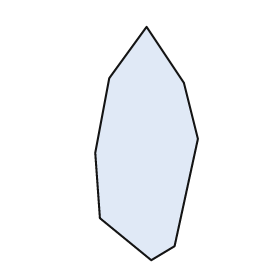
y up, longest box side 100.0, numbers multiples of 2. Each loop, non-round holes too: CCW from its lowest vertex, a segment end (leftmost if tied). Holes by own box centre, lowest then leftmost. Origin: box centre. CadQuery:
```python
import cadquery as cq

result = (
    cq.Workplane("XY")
    .moveTo(2.0, -50.0)
    .lineTo(12.0, -44.0)
    .lineTo(22.0, 2.0)
    .lineTo(16.0, 26.0)
    .lineTo(0.0, 50.0)
    .lineTo(-16.0, 28.0)
    .lineTo(-22.0, -4.0)
    .lineTo(-20.0, -32.0)
    .close()
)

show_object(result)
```